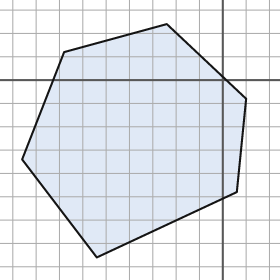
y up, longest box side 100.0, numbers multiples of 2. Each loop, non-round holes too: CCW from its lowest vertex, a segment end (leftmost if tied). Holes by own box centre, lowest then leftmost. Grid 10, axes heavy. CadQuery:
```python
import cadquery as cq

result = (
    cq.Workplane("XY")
    .moveTo(-54.0, -76.0)
    .lineTo(6.0, -48.0)
    .lineTo(10.0, -8.0)
    .lineTo(-24.0, 24.0)
    .lineTo(-68.0, 12.0)
    .lineTo(-86.0, -34.0)
    .close()
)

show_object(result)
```